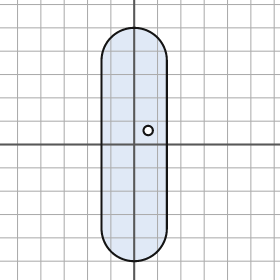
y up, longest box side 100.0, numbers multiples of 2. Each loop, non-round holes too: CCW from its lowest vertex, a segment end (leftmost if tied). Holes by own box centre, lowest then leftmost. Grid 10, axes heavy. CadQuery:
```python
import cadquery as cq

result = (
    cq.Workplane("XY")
    .moveTo(-14.0, -36.0)
    .threePointArc((0.0, -50.0), (14.0, -36.0))
    .lineTo(14.0, 36.0)
    .threePointArc((0.0, 50.0), (-14.0, 36.0))
    .close()
    .moveTo(6.0, 6.0)
    .circle(2.0)
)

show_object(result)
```